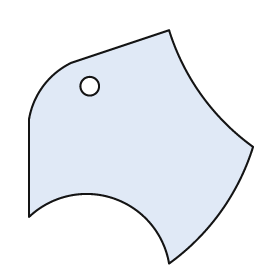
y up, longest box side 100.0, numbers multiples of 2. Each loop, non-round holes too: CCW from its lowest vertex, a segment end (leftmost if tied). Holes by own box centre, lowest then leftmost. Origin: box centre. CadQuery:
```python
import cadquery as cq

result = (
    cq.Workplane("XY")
    .moveTo(12.0, -50.0)
    .threePointArc((34.0, -28.0), (48.0, 0.0))
    .threePointArc((26.0, 22.0), (12.0, 50.0))
    .lineTo(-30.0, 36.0)
    .threePointArc((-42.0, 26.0), (-48.0, 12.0))
    .lineTo(-48.0, -30.0)
    .threePointArc((-12.0, -22.0), (12.0, -50.0))
    .close()
    .moveTo(-22.0, 26.0)
    .circle(4.0)
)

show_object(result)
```